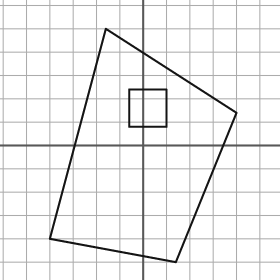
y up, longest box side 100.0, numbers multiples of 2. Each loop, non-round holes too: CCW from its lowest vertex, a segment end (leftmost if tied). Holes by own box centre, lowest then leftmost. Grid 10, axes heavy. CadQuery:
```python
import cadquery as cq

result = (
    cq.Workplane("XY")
    .moveTo(14.0, -50.0)
    .lineTo(40.0, 14.0)
    .lineTo(-16.0, 50.0)
    .lineTo(-40.0, -40.0)
    .close()
    .moveTo(-6.0, 8.0)
    .lineTo(10.0, 8.0)
    .lineTo(10.0, 24.0)
    .lineTo(-6.0, 24.0)
    .close()
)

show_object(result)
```